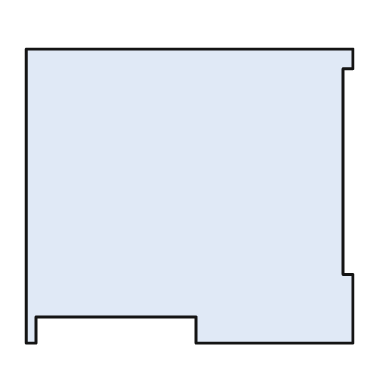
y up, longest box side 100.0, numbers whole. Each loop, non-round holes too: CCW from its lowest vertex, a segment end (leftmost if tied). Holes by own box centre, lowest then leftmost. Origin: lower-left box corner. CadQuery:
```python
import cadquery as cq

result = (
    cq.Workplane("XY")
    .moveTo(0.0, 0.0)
    .lineTo(3.0, 0.0)
    .lineTo(3.0, 8.0)
    .lineTo(52.0, 8.0)
    .lineTo(52.0, 0.0)
    .lineTo(100.0, 0.0)
    .lineTo(100.0, 21.0)
    .lineTo(97.0, 21.0)
    .lineTo(97.0, 84.0)
    .lineTo(100.0, 84.0)
    .lineTo(100.0, 90.0)
    .lineTo(0.0, 90.0)
    .close()
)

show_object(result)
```